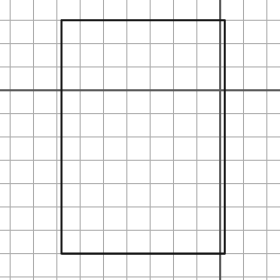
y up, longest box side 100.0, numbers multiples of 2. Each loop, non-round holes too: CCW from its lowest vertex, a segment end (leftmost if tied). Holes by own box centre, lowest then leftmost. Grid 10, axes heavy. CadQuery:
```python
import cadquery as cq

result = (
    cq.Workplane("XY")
    .moveTo(-68.0, -70.0)
    .lineTo(2.0, -70.0)
    .lineTo(2.0, 30.0)
    .lineTo(-68.0, 30.0)
    .close()
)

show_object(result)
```